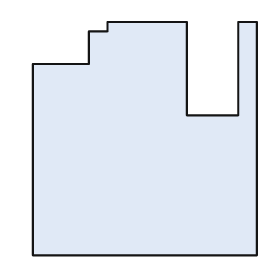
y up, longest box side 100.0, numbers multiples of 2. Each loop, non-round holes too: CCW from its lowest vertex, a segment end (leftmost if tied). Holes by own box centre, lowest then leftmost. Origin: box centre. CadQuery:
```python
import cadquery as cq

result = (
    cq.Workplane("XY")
    .moveTo(-48.0, -50.0)
    .lineTo(48.0, -50.0)
    .lineTo(48.0, 50.0)
    .lineTo(40.0, 50.0)
    .lineTo(40.0, 10.0)
    .lineTo(18.0, 10.0)
    .lineTo(18.0, 50.0)
    .lineTo(-16.0, 50.0)
    .lineTo(-16.0, 46.0)
    .lineTo(-24.0, 46.0)
    .lineTo(-24.0, 32.0)
    .lineTo(-48.0, 32.0)
    .close()
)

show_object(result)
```